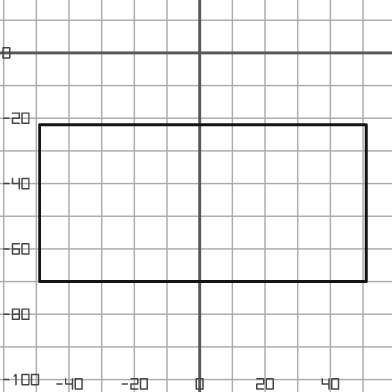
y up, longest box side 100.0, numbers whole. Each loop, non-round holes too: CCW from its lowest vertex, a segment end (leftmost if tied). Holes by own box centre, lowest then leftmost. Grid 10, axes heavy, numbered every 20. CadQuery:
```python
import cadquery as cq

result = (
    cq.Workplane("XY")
    .moveTo(-49.0, -70.0)
    .lineTo(51.0, -70.0)
    .lineTo(51.0, -22.0)
    .lineTo(-49.0, -22.0)
    .close()
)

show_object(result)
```